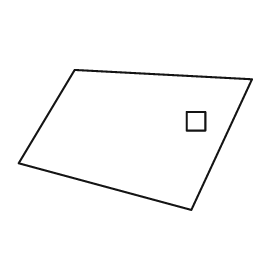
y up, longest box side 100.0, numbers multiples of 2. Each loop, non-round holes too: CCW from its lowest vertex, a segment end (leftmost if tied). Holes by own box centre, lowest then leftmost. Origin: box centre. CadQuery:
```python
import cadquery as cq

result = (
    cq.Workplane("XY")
    .moveTo(24.0, -30.0)
    .lineTo(50.0, 26.0)
    .lineTo(-26.0, 30.0)
    .lineTo(-50.0, -10.0)
    .close()
    .moveTo(22.0, 4.0)
    .lineTo(30.0, 4.0)
    .lineTo(30.0, 12.0)
    .lineTo(22.0, 12.0)
    .close()
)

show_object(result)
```